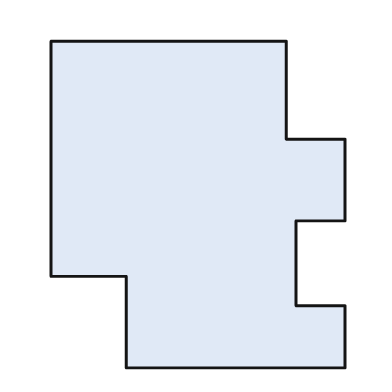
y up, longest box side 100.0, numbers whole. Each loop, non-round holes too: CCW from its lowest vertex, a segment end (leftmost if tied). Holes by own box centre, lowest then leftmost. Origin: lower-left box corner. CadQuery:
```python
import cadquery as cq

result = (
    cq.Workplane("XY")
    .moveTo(23.0, 0.0)
    .lineTo(90.0, 0.0)
    .lineTo(90.0, 19.0)
    .lineTo(75.0, 19.0)
    .lineTo(75.0, 45.0)
    .lineTo(90.0, 45.0)
    .lineTo(90.0, 70.0)
    .lineTo(72.0, 70.0)
    .lineTo(72.0, 100.0)
    .lineTo(0.0, 100.0)
    .lineTo(0.0, 28.0)
    .lineTo(23.0, 28.0)
    .close()
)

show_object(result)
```